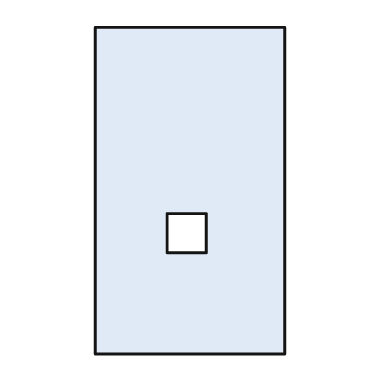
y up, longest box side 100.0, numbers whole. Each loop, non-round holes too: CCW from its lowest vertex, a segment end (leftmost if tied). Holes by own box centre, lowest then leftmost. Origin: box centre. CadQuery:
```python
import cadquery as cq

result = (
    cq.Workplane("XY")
    .moveTo(-29.0, -50.0)
    .lineTo(29.0, -50.0)
    .lineTo(29.0, 50.0)
    .lineTo(-29.0, 50.0)
    .close()
    .moveTo(-7.0, -19.0)
    .lineTo(5.0, -19.0)
    .lineTo(5.0, -7.0)
    .lineTo(-7.0, -7.0)
    .close()
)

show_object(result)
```